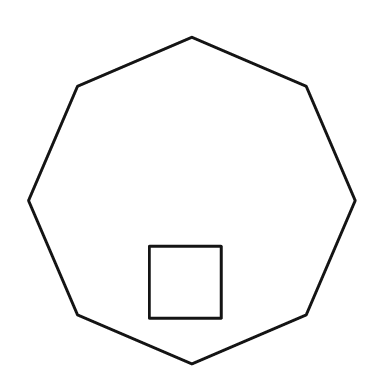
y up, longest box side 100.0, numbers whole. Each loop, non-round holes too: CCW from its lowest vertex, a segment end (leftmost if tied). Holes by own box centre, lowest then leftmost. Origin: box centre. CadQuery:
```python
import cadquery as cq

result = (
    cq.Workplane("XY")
    .moveTo(0.0, -50.0)
    .lineTo(35.0, -35.0)
    .lineTo(50.0, 0.0)
    .lineTo(35.0, 35.0)
    .lineTo(0.0, 50.0)
    .lineTo(-35.0, 35.0)
    .lineTo(-50.0, 0.0)
    .lineTo(-35.0, -35.0)
    .close()
    .moveTo(-13.0, -36.0)
    .lineTo(9.0, -36.0)
    .lineTo(9.0, -14.0)
    .lineTo(-13.0, -14.0)
    .close()
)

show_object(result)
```